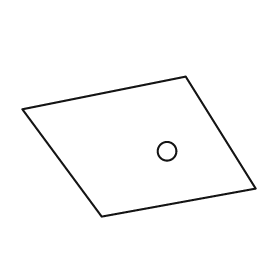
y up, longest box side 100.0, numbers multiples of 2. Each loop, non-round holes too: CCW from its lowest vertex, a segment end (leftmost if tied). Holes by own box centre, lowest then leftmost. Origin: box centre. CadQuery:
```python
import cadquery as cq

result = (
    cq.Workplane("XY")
    .moveTo(-16.0, -30.0)
    .lineTo(50.0, -18.0)
    .lineTo(20.0, 30.0)
    .lineTo(-50.0, 16.0)
    .close()
    .moveTo(12.0, -2.0)
    .circle(4.0)
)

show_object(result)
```